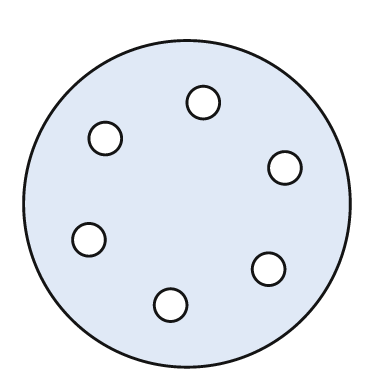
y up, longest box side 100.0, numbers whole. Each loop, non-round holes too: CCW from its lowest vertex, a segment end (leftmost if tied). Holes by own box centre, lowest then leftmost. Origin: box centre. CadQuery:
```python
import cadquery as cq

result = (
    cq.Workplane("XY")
    .moveTo(0.0, 0.0)
    .circle(50.0)
    .moveTo(-5.0, -31.0)
    .circle(5.0)
    .moveTo(25.0, -20.0)
    .circle(5.0)
    .moveTo(-30.0, -11.0)
    .circle(5.0)
    .moveTo(30.0, 11.0)
    .circle(5.0)
    .moveTo(-25.0, 20.0)
    .circle(5.0)
    .moveTo(5.0, 31.0)
    .circle(5.0)
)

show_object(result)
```